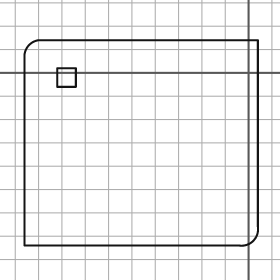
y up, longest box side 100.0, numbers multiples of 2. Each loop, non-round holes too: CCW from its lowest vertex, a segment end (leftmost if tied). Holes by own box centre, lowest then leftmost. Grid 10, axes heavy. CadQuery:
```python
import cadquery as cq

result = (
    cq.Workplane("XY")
    .moveTo(-96.0, -74.0)
    .lineTo(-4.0, -74.0)
    .threePointArc((2.0, -72.0), (4.0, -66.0))
    .lineTo(4.0, 14.0)
    .lineTo(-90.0, 14.0)
    .threePointArc((-94.0, 12.0), (-96.0, 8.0))
    .close()
    .moveTo(-82.0, -6.0)
    .lineTo(-74.0, -6.0)
    .lineTo(-74.0, 2.0)
    .lineTo(-82.0, 2.0)
    .close()
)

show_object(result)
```